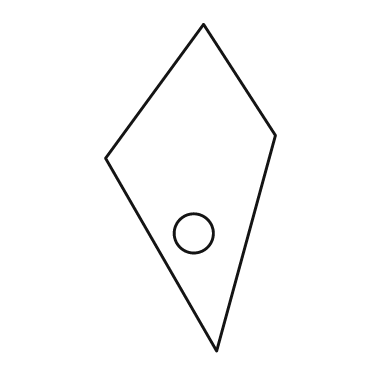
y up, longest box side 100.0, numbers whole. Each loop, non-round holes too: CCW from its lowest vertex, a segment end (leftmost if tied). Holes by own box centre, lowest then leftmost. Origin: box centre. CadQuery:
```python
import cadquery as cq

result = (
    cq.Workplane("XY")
    .moveTo(8.0, -50.0)
    .lineTo(26.0, 16.0)
    .lineTo(4.0, 50.0)
    .lineTo(-26.0, 9.0)
    .close()
    .moveTo(1.0, -14.0)
    .circle(6.0)
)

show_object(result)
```